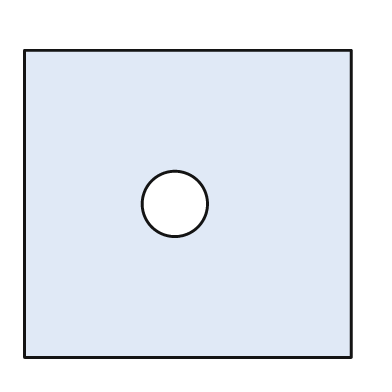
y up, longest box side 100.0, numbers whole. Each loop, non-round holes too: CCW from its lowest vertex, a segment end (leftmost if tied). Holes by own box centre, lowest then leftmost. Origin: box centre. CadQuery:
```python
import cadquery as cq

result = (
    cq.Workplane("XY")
    .moveTo(-50.0, -47.0)
    .lineTo(50.0, -47.0)
    .lineTo(50.0, 47.0)
    .lineTo(-50.0, 47.0)
    .close()
    .moveTo(-4.0, 0.0)
    .circle(10.0)
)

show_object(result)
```